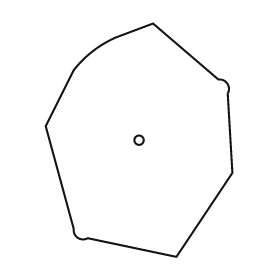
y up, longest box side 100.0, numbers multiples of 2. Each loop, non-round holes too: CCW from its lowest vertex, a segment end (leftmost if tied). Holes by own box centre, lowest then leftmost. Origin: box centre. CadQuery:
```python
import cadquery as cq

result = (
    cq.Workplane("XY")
    .moveTo(16.0, -50.0)
    .lineTo(40.0, -14.0)
    .lineTo(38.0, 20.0)
    .threePointArc((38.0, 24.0), (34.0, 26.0))
    .lineTo(6.0, 50.0)
    .lineTo(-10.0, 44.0)
    .threePointArc((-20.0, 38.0), (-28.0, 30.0))
    .lineTo(-40.0, 6.0)
    .lineTo(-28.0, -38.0)
    .threePointArc((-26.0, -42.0), (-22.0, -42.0))
    .close()
    .moveTo(0.0, 0.0)
    .circle(2.0)
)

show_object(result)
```